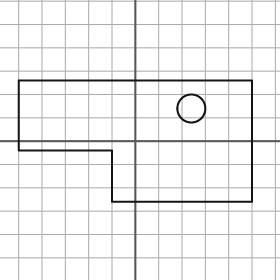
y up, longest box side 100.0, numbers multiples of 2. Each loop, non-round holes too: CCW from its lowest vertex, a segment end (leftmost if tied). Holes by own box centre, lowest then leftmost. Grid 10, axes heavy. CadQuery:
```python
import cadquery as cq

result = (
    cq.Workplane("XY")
    .moveTo(-10.0, -26.0)
    .lineTo(50.0, -26.0)
    .lineTo(50.0, 26.0)
    .lineTo(-50.0, 26.0)
    .lineTo(-50.0, -4.0)
    .lineTo(-10.0, -4.0)
    .close()
    .moveTo(24.0, 14.0)
    .circle(6.0)
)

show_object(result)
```